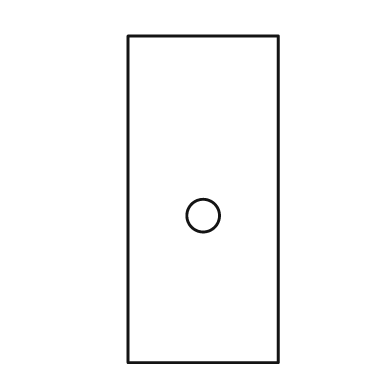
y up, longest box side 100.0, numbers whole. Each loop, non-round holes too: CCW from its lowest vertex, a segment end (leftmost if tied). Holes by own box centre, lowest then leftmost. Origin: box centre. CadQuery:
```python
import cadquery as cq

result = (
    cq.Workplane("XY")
    .moveTo(-23.0, -50.0)
    .lineTo(23.0, -50.0)
    .lineTo(23.0, 50.0)
    .lineTo(-23.0, 50.0)
    .close()
    .moveTo(0.0, -5.0)
    .circle(5.0)
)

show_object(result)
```